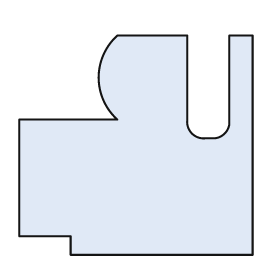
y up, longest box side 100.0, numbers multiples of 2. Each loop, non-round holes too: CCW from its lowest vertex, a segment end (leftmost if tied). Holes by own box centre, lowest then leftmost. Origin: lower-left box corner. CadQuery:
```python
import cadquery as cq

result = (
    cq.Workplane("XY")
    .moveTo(22.0, 0.0)
    .lineTo(100.0, 0.0)
    .lineTo(100.0, 94.0)
    .lineTo(90.0, 94.0)
    .lineTo(90.0, 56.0)
    .threePointArc((88.0, 52.0), (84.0, 50.0))
    .lineTo(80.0, 50.0)
    .threePointArc((74.0, 52.0), (72.0, 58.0))
    .lineTo(72.0, 94.0)
    .lineTo(42.0, 94.0)
    .threePointArc((34.0, 76.0), (42.0, 58.0))
    .lineTo(0.0, 58.0)
    .lineTo(0.0, 8.0)
    .lineTo(22.0, 8.0)
    .close()
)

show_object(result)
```